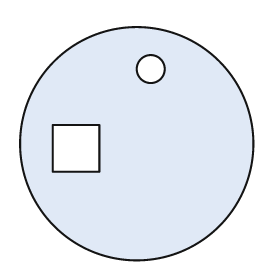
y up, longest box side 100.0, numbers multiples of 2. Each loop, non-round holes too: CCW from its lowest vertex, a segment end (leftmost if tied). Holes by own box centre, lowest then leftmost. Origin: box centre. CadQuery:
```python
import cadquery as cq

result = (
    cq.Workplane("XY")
    .moveTo(0.0, 0.0)
    .circle(50.0)
    .moveTo(-36.0, -12.0)
    .lineTo(-16.0, -12.0)
    .lineTo(-16.0, 8.0)
    .lineTo(-36.0, 8.0)
    .close()
    .moveTo(6.0, 32.0)
    .circle(6.0)
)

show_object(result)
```